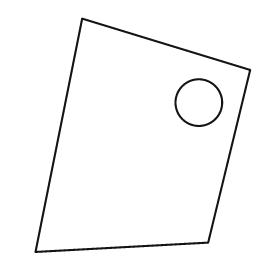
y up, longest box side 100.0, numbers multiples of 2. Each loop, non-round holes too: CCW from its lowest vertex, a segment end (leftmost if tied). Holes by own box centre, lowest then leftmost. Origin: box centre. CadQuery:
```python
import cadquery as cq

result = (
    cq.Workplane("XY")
    .moveTo(-46.0, -50.0)
    .lineTo(28.0, -46.0)
    .lineTo(46.0, 28.0)
    .lineTo(-26.0, 50.0)
    .close()
    .moveTo(24.0, 14.0)
    .circle(10.0)
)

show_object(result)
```